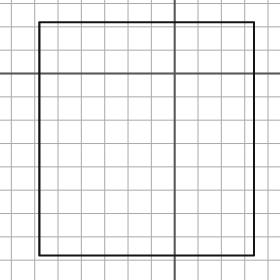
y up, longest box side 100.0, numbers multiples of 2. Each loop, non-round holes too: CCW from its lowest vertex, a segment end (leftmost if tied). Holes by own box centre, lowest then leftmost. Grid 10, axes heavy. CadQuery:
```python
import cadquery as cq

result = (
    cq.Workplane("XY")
    .moveTo(-58.0, -78.0)
    .lineTo(34.0, -78.0)
    .lineTo(34.0, 22.0)
    .lineTo(-58.0, 22.0)
    .close()
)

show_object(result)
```